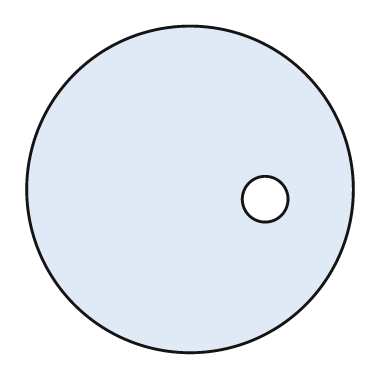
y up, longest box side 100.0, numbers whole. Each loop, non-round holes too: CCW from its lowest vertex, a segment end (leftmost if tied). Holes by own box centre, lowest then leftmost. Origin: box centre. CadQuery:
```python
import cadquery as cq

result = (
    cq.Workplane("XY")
    .moveTo(0.0, 0.0)
    .circle(50.0)
    .moveTo(23.0, -3.0)
    .circle(7.0)
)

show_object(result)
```